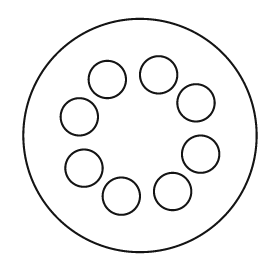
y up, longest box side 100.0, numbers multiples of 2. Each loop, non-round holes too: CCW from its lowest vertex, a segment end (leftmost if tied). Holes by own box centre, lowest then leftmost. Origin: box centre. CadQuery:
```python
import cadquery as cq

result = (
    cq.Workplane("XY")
    .moveTo(0.0, 0.0)
    .circle(50.0)
    .moveTo(-8.0, -26.0)
    .circle(8.0)
    .moveTo(14.0, -24.0)
    .circle(8.0)
    .moveTo(-24.0, -14.0)
    .circle(8.0)
    .moveTo(26.0, -8.0)
    .circle(8.0)
    .moveTo(-26.0, 8.0)
    .circle(8.0)
    .moveTo(24.0, 14.0)
    .circle(8.0)
    .moveTo(-14.0, 24.0)
    .circle(8.0)
    .moveTo(8.0, 26.0)
    .circle(8.0)
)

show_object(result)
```